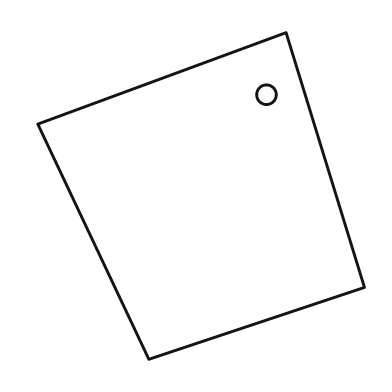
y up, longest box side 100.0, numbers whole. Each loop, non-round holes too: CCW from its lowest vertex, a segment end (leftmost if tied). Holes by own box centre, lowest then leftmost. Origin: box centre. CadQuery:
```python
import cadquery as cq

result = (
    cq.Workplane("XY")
    .moveTo(-16.0, -50.0)
    .lineTo(50.0, -28.0)
    .lineTo(26.0, 50.0)
    .lineTo(-50.0, 22.0)
    .close()
    .moveTo(20.0, 31.0)
    .circle(3.0)
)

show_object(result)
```